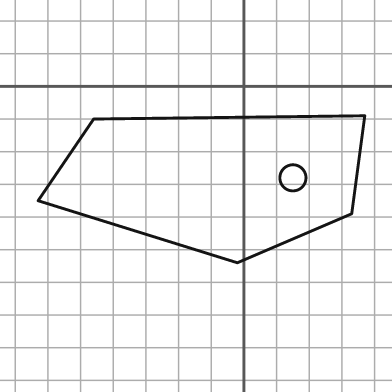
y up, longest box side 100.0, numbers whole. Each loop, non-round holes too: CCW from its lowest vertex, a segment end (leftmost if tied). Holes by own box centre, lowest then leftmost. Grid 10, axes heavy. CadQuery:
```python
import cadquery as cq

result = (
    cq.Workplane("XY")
    .moveTo(-2.0, -54.0)
    .lineTo(33.0, -39.0)
    .lineTo(37.0, -9.0)
    .lineTo(-46.0, -10.0)
    .lineTo(-63.0, -35.0)
    .close()
    .moveTo(15.0, -28.0)
    .circle(4.0)
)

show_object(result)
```